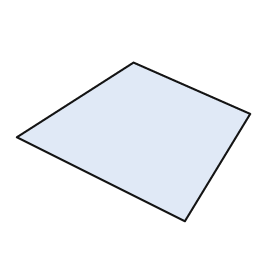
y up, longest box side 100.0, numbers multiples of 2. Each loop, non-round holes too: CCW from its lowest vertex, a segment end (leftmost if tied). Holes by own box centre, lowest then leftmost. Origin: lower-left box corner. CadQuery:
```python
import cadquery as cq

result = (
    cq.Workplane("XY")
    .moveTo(72.0, 0.0)
    .lineTo(100.0, 46.0)
    .lineTo(50.0, 68.0)
    .lineTo(0.0, 36.0)
    .close()
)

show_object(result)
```